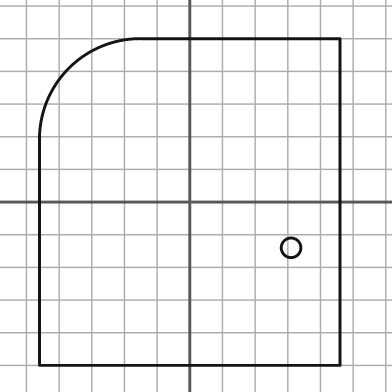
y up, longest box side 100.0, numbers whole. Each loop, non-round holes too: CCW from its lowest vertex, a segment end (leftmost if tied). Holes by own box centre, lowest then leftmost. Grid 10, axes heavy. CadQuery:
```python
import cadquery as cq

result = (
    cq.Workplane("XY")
    .moveTo(-46.0, -50.0)
    .lineTo(46.0, -50.0)
    .lineTo(46.0, 50.0)
    .lineTo(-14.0, 50.0)
    .threePointArc((-37.0, 41.0), (-46.0, 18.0))
    .close()
    .moveTo(31.0, -14.0)
    .circle(3.0)
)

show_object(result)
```